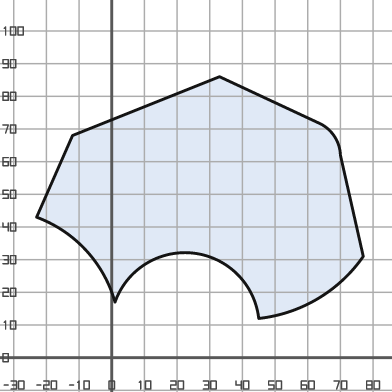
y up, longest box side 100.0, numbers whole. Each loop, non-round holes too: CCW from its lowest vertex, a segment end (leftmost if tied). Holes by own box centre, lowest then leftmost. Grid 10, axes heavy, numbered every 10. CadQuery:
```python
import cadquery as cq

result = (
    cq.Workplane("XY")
    .moveTo(45.0, 12.0)
    .threePointArc((63.0, 18.0), (77.0, 31.0))
    .lineTo(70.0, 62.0)
    .threePointArc((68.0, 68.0), (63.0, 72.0))
    .lineTo(33.0, 86.0)
    .lineTo(-12.0, 68.0)
    .lineTo(-23.0, 43.0)
    .threePointArc((-8.0, 33.0), (1.0, 17.0))
    .threePointArc((25.0, 32.0), (45.0, 12.0))
    .close()
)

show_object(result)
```